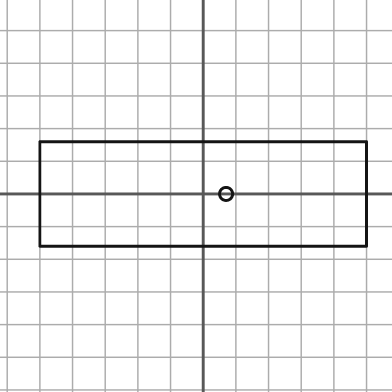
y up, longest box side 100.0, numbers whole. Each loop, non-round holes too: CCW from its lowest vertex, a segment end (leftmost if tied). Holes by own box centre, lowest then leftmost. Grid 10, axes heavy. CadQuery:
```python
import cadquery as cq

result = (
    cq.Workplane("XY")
    .moveTo(-50.0, -16.0)
    .lineTo(50.0, -16.0)
    .lineTo(50.0, 16.0)
    .lineTo(-50.0, 16.0)
    .close()
    .moveTo(7.0, 0.0)
    .circle(2.0)
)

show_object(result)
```